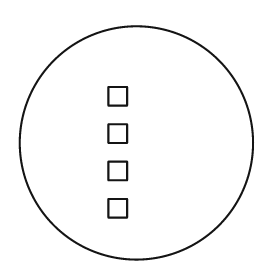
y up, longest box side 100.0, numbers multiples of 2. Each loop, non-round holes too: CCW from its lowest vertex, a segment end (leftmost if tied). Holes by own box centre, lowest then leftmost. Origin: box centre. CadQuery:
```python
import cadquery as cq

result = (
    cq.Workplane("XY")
    .moveTo(0.0, 0.0)
    .circle(50.0)
    .moveTo(-12.0, -32.0)
    .lineTo(-4.0, -32.0)
    .lineTo(-4.0, -24.0)
    .lineTo(-12.0, -24.0)
    .close()
    .moveTo(-12.0, -16.0)
    .lineTo(-4.0, -16.0)
    .lineTo(-4.0, -8.0)
    .lineTo(-12.0, -8.0)
    .close()
    .moveTo(-12.0, 0.0)
    .lineTo(-4.0, 0.0)
    .lineTo(-4.0, 8.0)
    .lineTo(-12.0, 8.0)
    .close()
    .moveTo(-12.0, 16.0)
    .lineTo(-4.0, 16.0)
    .lineTo(-4.0, 24.0)
    .lineTo(-12.0, 24.0)
    .close()
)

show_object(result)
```